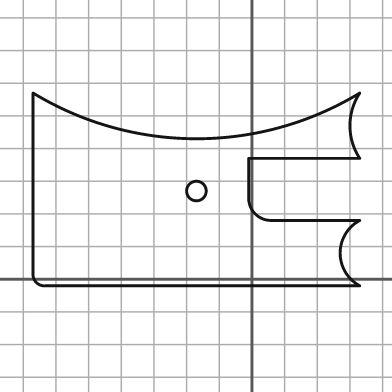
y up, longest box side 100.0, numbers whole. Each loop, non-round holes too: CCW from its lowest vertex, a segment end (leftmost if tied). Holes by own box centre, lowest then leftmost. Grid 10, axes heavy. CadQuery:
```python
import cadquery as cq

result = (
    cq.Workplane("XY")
    .moveTo(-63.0, -2.0)
    .lineTo(33.0, -2.0)
    .threePointArc((27.0, 8.0), (33.0, 18.0))
    .lineTo(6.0, 18.0)
    .threePointArc((1.0, 20.0), (-1.0, 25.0))
    .lineTo(-1.0, 37.0)
    .lineTo(33.0, 37.0)
    .threePointArc((30.0, 47.0), (33.0, 57.0))
    .threePointArc((-17.0, 43.0), (-67.0, 57.0))
    .lineTo(-67.0, 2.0)
    .threePointArc((-66.0, -1.0), (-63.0, -2.0))
    .close()
    .moveTo(-17.0, 27.0)
    .circle(3.0)
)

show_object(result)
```